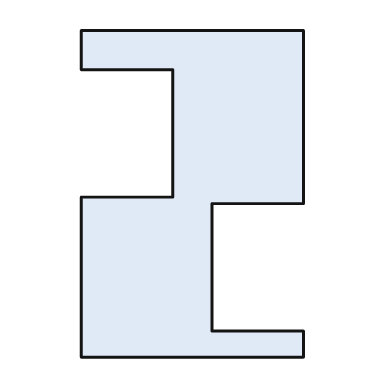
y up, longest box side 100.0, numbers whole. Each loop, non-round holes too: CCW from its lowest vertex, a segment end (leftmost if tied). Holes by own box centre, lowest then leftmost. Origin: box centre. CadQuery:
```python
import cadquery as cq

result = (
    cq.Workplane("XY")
    .moveTo(-34.0, -50.0)
    .lineTo(34.0, -50.0)
    .lineTo(34.0, -42.0)
    .lineTo(6.0, -42.0)
    .lineTo(6.0, -3.0)
    .lineTo(34.0, -3.0)
    .lineTo(34.0, 50.0)
    .lineTo(-34.0, 50.0)
    .lineTo(-34.0, 38.0)
    .lineTo(-6.0, 38.0)
    .lineTo(-6.0, -1.0)
    .lineTo(-34.0, -1.0)
    .close()
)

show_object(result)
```